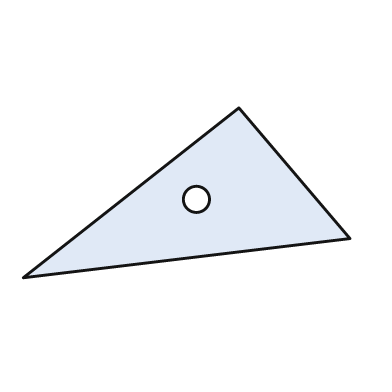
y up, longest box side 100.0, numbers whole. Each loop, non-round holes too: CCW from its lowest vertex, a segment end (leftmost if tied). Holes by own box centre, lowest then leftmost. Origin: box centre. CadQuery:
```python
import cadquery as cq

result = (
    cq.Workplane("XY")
    .moveTo(-50.0, -26.0)
    .lineTo(50.0, -14.0)
    .lineTo(16.0, 26.0)
    .close()
    .moveTo(3.0, -2.0)
    .circle(4.0)
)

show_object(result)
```